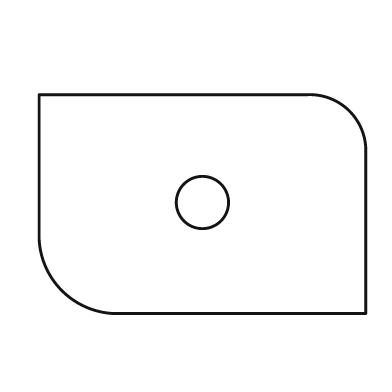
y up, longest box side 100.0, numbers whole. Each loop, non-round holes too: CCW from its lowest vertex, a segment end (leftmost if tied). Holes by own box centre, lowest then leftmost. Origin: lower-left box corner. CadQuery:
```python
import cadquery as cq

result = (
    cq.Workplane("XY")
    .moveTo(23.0, 0.0)
    .lineTo(100.0, 0.0)
    .lineTo(100.0, 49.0)
    .threePointArc((95.0, 62.0), (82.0, 67.0))
    .lineTo(0.0, 67.0)
    .lineTo(0.0, 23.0)
    .threePointArc((7.0, 7.0), (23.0, 0.0))
    .close()
    .moveTo(50.0, 34.0)
    .circle(8.0)
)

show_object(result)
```